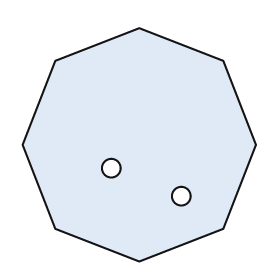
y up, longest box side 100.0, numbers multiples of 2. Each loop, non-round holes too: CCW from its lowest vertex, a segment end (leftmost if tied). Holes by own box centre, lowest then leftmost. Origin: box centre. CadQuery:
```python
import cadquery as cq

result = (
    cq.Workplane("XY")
    .moveTo(0.0, -50.0)
    .lineTo(36.0, -36.0)
    .lineTo(50.0, 0.0)
    .lineTo(36.0, 36.0)
    .lineTo(0.0, 50.0)
    .lineTo(-36.0, 36.0)
    .lineTo(-50.0, 0.0)
    .lineTo(-36.0, -36.0)
    .close()
    .moveTo(18.0, -22.0)
    .circle(4.0)
    .moveTo(-12.0, -10.0)
    .circle(4.0)
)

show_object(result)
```